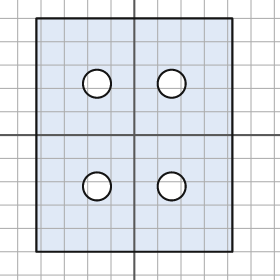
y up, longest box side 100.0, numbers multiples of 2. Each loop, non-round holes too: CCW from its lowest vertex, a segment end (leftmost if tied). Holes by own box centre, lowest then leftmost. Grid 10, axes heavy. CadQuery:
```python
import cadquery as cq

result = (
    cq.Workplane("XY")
    .moveTo(-42.0, -50.0)
    .lineTo(42.0, -50.0)
    .lineTo(42.0, 50.0)
    .lineTo(-42.0, 50.0)
    .close()
    .moveTo(-16.0, -22.0)
    .circle(6.0)
    .moveTo(16.0, -22.0)
    .circle(6.0)
    .moveTo(-16.0, 22.0)
    .circle(6.0)
    .moveTo(16.0, 22.0)
    .circle(6.0)
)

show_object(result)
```